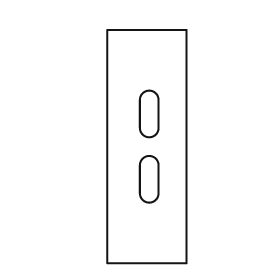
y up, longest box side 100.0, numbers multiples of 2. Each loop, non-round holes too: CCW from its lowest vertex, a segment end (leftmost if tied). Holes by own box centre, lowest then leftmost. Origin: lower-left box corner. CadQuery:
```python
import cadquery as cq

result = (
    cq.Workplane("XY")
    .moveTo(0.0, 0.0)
    .lineTo(34.0, 0.0)
    .lineTo(34.0, 100.0)
    .lineTo(0.0, 100.0)
    .close()
    .moveTo(14.0, 30.0)
    .threePointArc((18.0, 26.0), (22.0, 30.0))
    .lineTo(22.0, 42.0)
    .threePointArc((18.0, 46.0), (14.0, 42.0))
    .close()
    .moveTo(14.0, 58.0)
    .threePointArc((18.0, 54.0), (22.0, 58.0))
    .lineTo(22.0, 70.0)
    .threePointArc((18.0, 74.0), (14.0, 70.0))
    .close()
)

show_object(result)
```